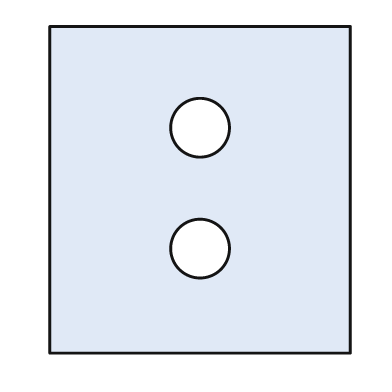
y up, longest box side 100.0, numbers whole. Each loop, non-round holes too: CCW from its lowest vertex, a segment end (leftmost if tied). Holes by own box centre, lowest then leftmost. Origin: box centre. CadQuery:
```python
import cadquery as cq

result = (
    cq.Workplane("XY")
    .moveTo(-46.0, -50.0)
    .lineTo(46.0, -50.0)
    .lineTo(46.0, 50.0)
    .lineTo(-46.0, 50.0)
    .close()
    .moveTo(0.0, -18.0)
    .circle(9.0)
    .moveTo(0.0, 19.0)
    .circle(9.0)
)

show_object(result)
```